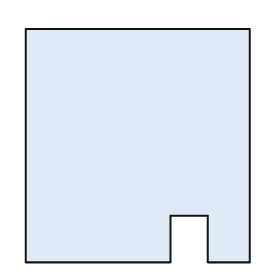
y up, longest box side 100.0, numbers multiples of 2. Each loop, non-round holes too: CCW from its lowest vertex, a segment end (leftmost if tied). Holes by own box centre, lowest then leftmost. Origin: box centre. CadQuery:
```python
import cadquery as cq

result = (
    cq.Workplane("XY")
    .moveTo(-48.0, -50.0)
    .lineTo(14.0, -50.0)
    .lineTo(14.0, -30.0)
    .lineTo(30.0, -30.0)
    .lineTo(30.0, -50.0)
    .lineTo(48.0, -50.0)
    .lineTo(48.0, 50.0)
    .lineTo(-48.0, 50.0)
    .close()
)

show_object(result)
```